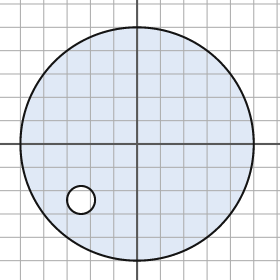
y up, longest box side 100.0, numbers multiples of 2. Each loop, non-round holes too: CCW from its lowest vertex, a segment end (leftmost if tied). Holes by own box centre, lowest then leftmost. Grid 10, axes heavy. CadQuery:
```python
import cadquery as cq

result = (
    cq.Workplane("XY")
    .moveTo(0.0, 0.0)
    .circle(50.0)
    .moveTo(-24.0, -24.0)
    .circle(6.0)
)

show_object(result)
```